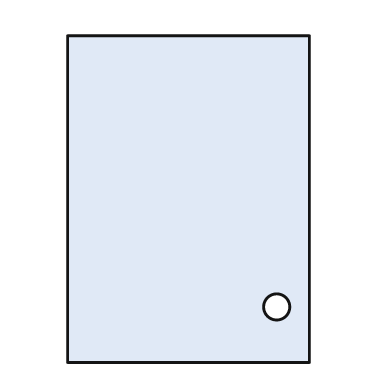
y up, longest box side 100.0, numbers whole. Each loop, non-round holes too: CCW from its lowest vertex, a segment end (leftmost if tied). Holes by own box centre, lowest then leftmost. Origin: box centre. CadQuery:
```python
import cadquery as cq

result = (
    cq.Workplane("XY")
    .moveTo(-37.0, -50.0)
    .lineTo(37.0, -50.0)
    .lineTo(37.0, 50.0)
    .lineTo(-37.0, 50.0)
    .close()
    .moveTo(27.0, -33.0)
    .circle(4.0)
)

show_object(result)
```